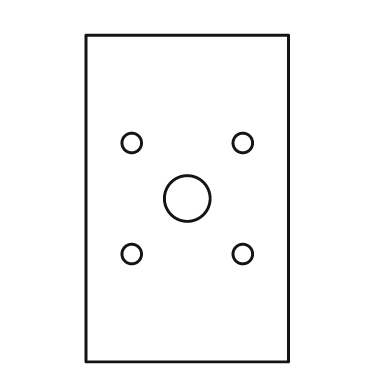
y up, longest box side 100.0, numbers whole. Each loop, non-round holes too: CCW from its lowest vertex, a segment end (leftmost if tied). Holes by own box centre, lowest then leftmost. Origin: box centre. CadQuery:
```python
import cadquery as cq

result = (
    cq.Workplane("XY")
    .moveTo(-31.0, -50.0)
    .lineTo(31.0, -50.0)
    .lineTo(31.0, 50.0)
    .lineTo(-31.0, 50.0)
    .close()
    .moveTo(-17.0, -17.0)
    .circle(3.0)
    .moveTo(17.0, -17.0)
    .circle(3.0)
    .moveTo(0.0, 0.0)
    .circle(7.0)
    .moveTo(-17.0, 17.0)
    .circle(3.0)
    .moveTo(17.0, 17.0)
    .circle(3.0)
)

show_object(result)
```